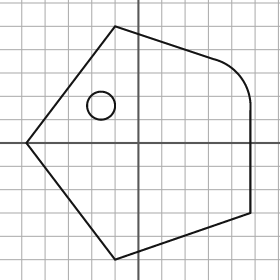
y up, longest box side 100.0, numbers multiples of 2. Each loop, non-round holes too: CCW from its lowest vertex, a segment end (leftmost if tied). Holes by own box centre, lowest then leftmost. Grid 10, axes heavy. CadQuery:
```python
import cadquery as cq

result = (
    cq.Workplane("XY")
    .moveTo(-10.0, -50.0)
    .lineTo(48.0, -30.0)
    .lineTo(48.0, 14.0)
    .threePointArc((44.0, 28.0), (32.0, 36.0))
    .lineTo(-10.0, 50.0)
    .lineTo(-48.0, 0.0)
    .close()
    .moveTo(-16.0, 16.0)
    .circle(6.0)
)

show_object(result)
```